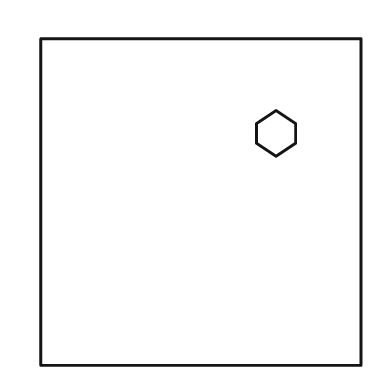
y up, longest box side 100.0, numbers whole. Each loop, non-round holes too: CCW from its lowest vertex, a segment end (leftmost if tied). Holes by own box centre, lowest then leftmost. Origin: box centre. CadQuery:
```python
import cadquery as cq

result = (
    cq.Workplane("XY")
    .moveTo(-49.0, -50.0)
    .lineTo(49.0, -50.0)
    .lineTo(49.0, 50.0)
    .lineTo(-49.0, 50.0)
    .close()
    .moveTo(23.0, 14.0)
    .lineTo(29.0, 18.0)
    .lineTo(29.0, 24.0)
    .lineTo(23.0, 28.0)
    .lineTo(17.0, 24.0)
    .lineTo(17.0, 18.0)
    .close()
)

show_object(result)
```